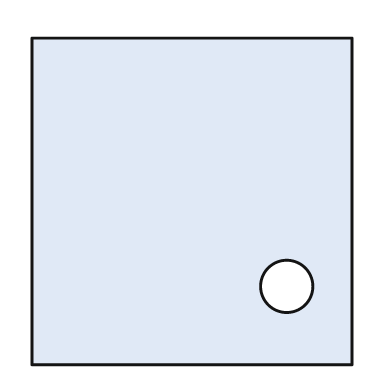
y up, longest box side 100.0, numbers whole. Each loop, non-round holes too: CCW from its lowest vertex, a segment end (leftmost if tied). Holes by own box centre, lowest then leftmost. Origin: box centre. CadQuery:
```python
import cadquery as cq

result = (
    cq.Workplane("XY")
    .moveTo(-49.0, -50.0)
    .lineTo(49.0, -50.0)
    .lineTo(49.0, 50.0)
    .lineTo(-49.0, 50.0)
    .close()
    .moveTo(29.0, -26.0)
    .circle(8.0)
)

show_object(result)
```